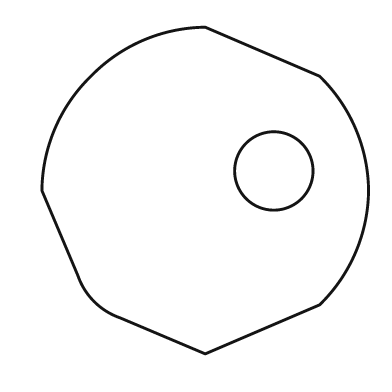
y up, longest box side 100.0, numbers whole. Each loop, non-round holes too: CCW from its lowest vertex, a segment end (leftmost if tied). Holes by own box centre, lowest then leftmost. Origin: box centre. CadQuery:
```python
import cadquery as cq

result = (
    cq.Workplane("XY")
    .moveTo(0.0, -50.0)
    .lineTo(35.0, -35.0)
    .threePointArc((46.0, -19.0), (50.0, 0.0))
    .threePointArc((46.0, 19.0), (35.0, 35.0))
    .lineTo(0.0, 50.0)
    .threePointArc((-19.0, 46.0), (-35.0, 35.0))
    .threePointArc((-46.0, 19.0), (-50.0, 0.0))
    .lineTo(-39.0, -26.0)
    .threePointArc((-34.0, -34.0), (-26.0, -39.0))
    .close()
    .moveTo(21.0, 6.0)
    .circle(12.0)
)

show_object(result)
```